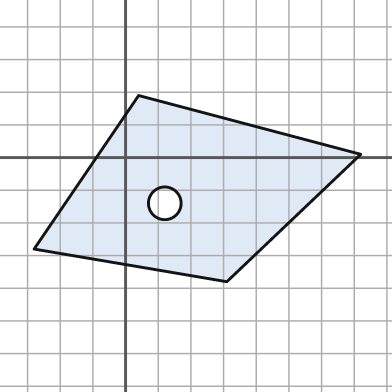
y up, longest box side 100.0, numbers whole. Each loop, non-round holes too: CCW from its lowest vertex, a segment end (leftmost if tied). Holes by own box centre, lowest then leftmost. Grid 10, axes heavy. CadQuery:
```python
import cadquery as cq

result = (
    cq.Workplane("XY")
    .moveTo(31.0, -38.0)
    .lineTo(72.0, 1.0)
    .lineTo(4.0, 19.0)
    .lineTo(-28.0, -28.0)
    .close()
    .moveTo(12.0, -14.0)
    .circle(5.0)
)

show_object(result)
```